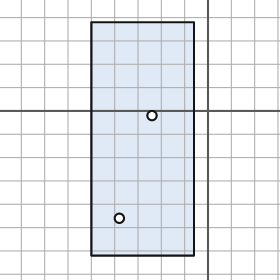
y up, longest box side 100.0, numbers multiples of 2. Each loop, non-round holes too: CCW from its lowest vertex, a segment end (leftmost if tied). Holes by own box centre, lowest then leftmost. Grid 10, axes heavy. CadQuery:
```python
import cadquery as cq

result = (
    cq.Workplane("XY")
    .moveTo(-50.0, -62.0)
    .lineTo(-6.0, -62.0)
    .lineTo(-6.0, 38.0)
    .lineTo(-50.0, 38.0)
    .close()
    .moveTo(-38.0, -46.0)
    .circle(2.0)
    .moveTo(-24.0, -2.0)
    .circle(2.0)
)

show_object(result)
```